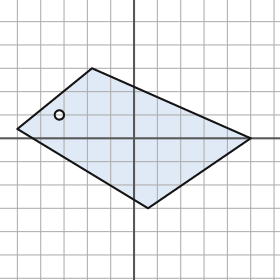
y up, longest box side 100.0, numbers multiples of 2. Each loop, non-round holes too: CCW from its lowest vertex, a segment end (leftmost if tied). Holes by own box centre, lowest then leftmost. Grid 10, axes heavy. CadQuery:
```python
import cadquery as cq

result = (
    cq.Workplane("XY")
    .moveTo(6.0, -30.0)
    .lineTo(50.0, 0.0)
    .lineTo(-18.0, 30.0)
    .lineTo(-50.0, 4.0)
    .close()
    .moveTo(-32.0, 10.0)
    .circle(2.0)
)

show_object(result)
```